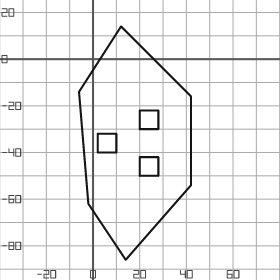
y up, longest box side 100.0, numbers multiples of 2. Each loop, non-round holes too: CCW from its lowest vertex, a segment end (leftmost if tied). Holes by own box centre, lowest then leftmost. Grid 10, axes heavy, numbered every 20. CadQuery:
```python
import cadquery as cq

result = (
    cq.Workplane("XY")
    .moveTo(14.0, -86.0)
    .lineTo(42.0, -54.0)
    .lineTo(42.0, -16.0)
    .lineTo(12.0, 14.0)
    .lineTo(-6.0, -14.0)
    .lineTo(-2.0, -62.0)
    .close()
    .moveTo(20.0, -50.0)
    .lineTo(28.0, -50.0)
    .lineTo(28.0, -42.0)
    .lineTo(20.0, -42.0)
    .close()
    .moveTo(2.0, -40.0)
    .lineTo(10.0, -40.0)
    .lineTo(10.0, -32.0)
    .lineTo(2.0, -32.0)
    .close()
    .moveTo(20.0, -30.0)
    .lineTo(28.0, -30.0)
    .lineTo(28.0, -22.0)
    .lineTo(20.0, -22.0)
    .close()
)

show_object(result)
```